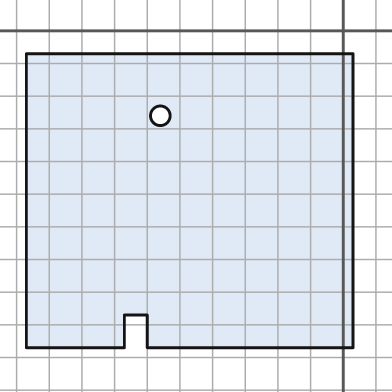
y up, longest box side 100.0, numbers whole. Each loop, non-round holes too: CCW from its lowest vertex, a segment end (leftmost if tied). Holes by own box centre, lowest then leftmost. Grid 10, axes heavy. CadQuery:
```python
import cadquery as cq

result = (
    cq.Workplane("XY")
    .moveTo(-97.0, -97.0)
    .lineTo(-67.0, -97.0)
    .lineTo(-67.0, -87.0)
    .lineTo(-60.0, -87.0)
    .lineTo(-60.0, -97.0)
    .lineTo(3.0, -97.0)
    .lineTo(3.0, -7.0)
    .lineTo(-97.0, -7.0)
    .close()
    .moveTo(-56.0, -26.0)
    .circle(3.0)
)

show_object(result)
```